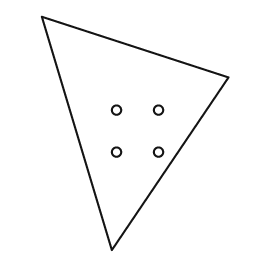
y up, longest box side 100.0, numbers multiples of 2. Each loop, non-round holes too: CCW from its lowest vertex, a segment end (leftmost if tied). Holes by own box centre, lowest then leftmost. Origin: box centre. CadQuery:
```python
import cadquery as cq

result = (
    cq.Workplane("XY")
    .moveTo(-10.0, -50.0)
    .lineTo(40.0, 24.0)
    .lineTo(-40.0, 50.0)
    .close()
    .moveTo(-8.0, -8.0)
    .circle(2.0)
    .moveTo(10.0, -8.0)
    .circle(2.0)
    .moveTo(-8.0, 10.0)
    .circle(2.0)
    .moveTo(10.0, 10.0)
    .circle(2.0)
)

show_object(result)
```